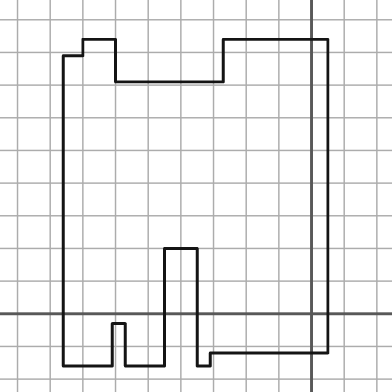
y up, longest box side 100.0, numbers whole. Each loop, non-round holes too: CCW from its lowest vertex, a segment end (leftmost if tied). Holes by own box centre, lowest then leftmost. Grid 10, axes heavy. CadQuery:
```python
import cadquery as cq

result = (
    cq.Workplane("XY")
    .moveTo(-76.0, -16.0)
    .lineTo(-61.0, -16.0)
    .lineTo(-61.0, -3.0)
    .lineTo(-57.0, -3.0)
    .lineTo(-57.0, -16.0)
    .lineTo(-45.0, -16.0)
    .lineTo(-45.0, 20.0)
    .lineTo(-35.0, 20.0)
    .lineTo(-35.0, -16.0)
    .lineTo(-31.0, -16.0)
    .lineTo(-31.0, -12.0)
    .lineTo(5.0, -12.0)
    .lineTo(5.0, 84.0)
    .lineTo(-27.0, 84.0)
    .lineTo(-27.0, 71.0)
    .lineTo(-60.0, 71.0)
    .lineTo(-60.0, 84.0)
    .lineTo(-70.0, 84.0)
    .lineTo(-70.0, 79.0)
    .lineTo(-76.0, 79.0)
    .close()
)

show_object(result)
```